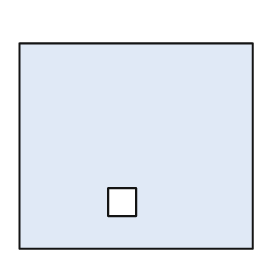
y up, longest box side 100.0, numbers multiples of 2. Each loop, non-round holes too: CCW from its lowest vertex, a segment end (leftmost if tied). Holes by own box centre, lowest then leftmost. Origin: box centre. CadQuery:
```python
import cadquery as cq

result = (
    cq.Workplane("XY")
    .moveTo(-50.0, -44.0)
    .lineTo(50.0, -44.0)
    .lineTo(50.0, 44.0)
    .lineTo(-50.0, 44.0)
    .close()
    .moveTo(-12.0, -30.0)
    .lineTo(0.0, -30.0)
    .lineTo(0.0, -18.0)
    .lineTo(-12.0, -18.0)
    .close()
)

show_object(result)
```